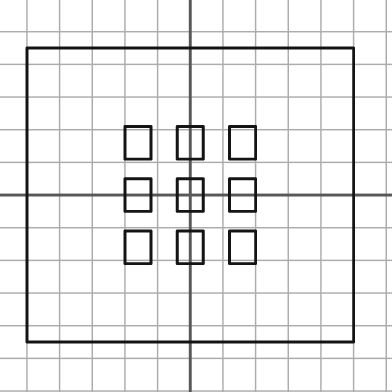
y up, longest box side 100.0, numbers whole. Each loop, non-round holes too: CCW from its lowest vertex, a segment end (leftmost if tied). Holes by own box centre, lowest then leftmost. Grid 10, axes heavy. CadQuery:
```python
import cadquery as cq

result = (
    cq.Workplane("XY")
    .moveTo(-50.0, -45.0)
    .lineTo(50.0, -45.0)
    .lineTo(50.0, 45.0)
    .lineTo(-50.0, 45.0)
    .close()
    .moveTo(-20.0, -21.0)
    .lineTo(-12.0, -21.0)
    .lineTo(-12.0, -11.0)
    .lineTo(-20.0, -11.0)
    .close()
    .moveTo(-4.0, -21.0)
    .lineTo(4.0, -21.0)
    .lineTo(4.0, -11.0)
    .lineTo(-4.0, -11.0)
    .close()
    .moveTo(12.0, -21.0)
    .lineTo(20.0, -21.0)
    .lineTo(20.0, -11.0)
    .lineTo(12.0, -11.0)
    .close()
    .moveTo(-20.0, -5.0)
    .lineTo(-12.0, -5.0)
    .lineTo(-12.0, 5.0)
    .lineTo(-20.0, 5.0)
    .close()
    .moveTo(-4.0, -5.0)
    .lineTo(4.0, -5.0)
    .lineTo(4.0, 5.0)
    .lineTo(-4.0, 5.0)
    .close()
    .moveTo(12.0, -5.0)
    .lineTo(20.0, -5.0)
    .lineTo(20.0, 5.0)
    .lineTo(12.0, 5.0)
    .close()
    .moveTo(-20.0, 11.0)
    .lineTo(-12.0, 11.0)
    .lineTo(-12.0, 21.0)
    .lineTo(-20.0, 21.0)
    .close()
    .moveTo(-4.0, 11.0)
    .lineTo(4.0, 11.0)
    .lineTo(4.0, 21.0)
    .lineTo(-4.0, 21.0)
    .close()
    .moveTo(12.0, 11.0)
    .lineTo(20.0, 11.0)
    .lineTo(20.0, 21.0)
    .lineTo(12.0, 21.0)
    .close()
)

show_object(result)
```